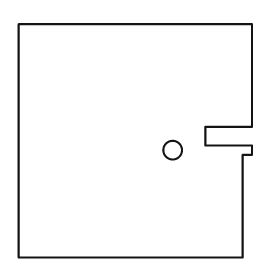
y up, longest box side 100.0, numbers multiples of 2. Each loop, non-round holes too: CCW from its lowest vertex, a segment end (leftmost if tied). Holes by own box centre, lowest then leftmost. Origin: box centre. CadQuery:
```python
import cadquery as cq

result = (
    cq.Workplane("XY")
    .moveTo(-50.0, -50.0)
    .lineTo(46.0, -50.0)
    .lineTo(46.0, -6.0)
    .lineTo(50.0, -6.0)
    .lineTo(50.0, -2.0)
    .lineTo(30.0, -2.0)
    .lineTo(30.0, 6.0)
    .lineTo(50.0, 6.0)
    .lineTo(50.0, 50.0)
    .lineTo(-50.0, 50.0)
    .close()
    .moveTo(16.0, -4.0)
    .circle(4.0)
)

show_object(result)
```